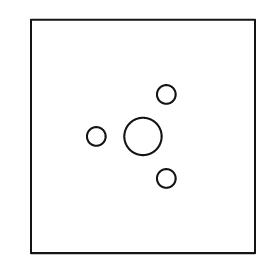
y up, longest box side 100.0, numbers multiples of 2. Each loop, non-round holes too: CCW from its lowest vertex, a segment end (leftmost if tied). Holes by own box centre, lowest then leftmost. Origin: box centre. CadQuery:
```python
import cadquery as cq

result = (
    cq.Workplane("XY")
    .moveTo(-48.0, -50.0)
    .lineTo(48.0, -50.0)
    .lineTo(48.0, 50.0)
    .lineTo(-48.0, 50.0)
    .close()
    .moveTo(10.0, -18.0)
    .circle(4.0)
    .moveTo(-20.0, 0.0)
    .circle(4.0)
    .moveTo(0.0, 0.0)
    .circle(8.0)
    .moveTo(10.0, 18.0)
    .circle(4.0)
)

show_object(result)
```